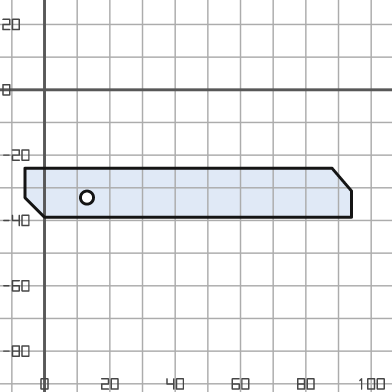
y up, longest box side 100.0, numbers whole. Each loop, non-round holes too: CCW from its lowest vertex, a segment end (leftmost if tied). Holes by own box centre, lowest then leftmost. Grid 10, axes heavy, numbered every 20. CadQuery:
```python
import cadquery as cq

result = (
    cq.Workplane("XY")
    .moveTo(0.0, -39.0)
    .lineTo(94.0, -39.0)
    .lineTo(94.0, -31.0)
    .lineTo(88.0, -24.0)
    .lineTo(-6.0, -24.0)
    .lineTo(-6.0, -33.0)
    .close()
    .moveTo(13.0, -33.0)
    .circle(2.0)
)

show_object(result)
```